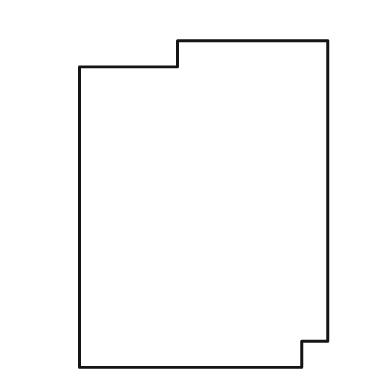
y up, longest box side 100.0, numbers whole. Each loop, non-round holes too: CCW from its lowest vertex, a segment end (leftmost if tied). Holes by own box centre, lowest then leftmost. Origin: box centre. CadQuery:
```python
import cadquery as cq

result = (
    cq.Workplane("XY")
    .moveTo(-38.0, -50.0)
    .lineTo(30.0, -50.0)
    .lineTo(30.0, -42.0)
    .lineTo(38.0, -42.0)
    .lineTo(38.0, 50.0)
    .lineTo(-8.0, 50.0)
    .lineTo(-8.0, 42.0)
    .lineTo(-38.0, 42.0)
    .close()
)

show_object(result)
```